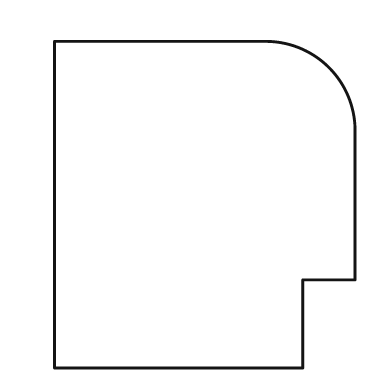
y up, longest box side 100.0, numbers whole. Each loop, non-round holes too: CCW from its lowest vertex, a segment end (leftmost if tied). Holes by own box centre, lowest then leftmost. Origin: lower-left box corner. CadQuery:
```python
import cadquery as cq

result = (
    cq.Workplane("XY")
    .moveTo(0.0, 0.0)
    .lineTo(76.0, 0.0)
    .lineTo(76.0, 27.0)
    .lineTo(92.0, 27.0)
    .lineTo(92.0, 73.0)
    .threePointArc((84.0, 92.0), (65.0, 100.0))
    .lineTo(0.0, 100.0)
    .close()
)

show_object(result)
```